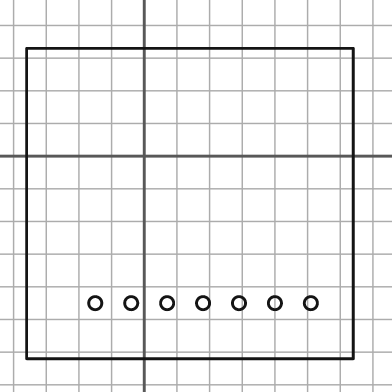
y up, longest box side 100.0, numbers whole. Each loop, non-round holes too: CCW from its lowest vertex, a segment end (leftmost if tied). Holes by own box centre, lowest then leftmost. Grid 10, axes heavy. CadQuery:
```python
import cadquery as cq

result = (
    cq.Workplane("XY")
    .moveTo(-36.0, -62.0)
    .lineTo(64.0, -62.0)
    .lineTo(64.0, 33.0)
    .lineTo(-36.0, 33.0)
    .close()
    .moveTo(-15.0, -45.0)
    .circle(2.0)
    .moveTo(-4.0, -45.0)
    .circle(2.0)
    .moveTo(7.0, -45.0)
    .circle(2.0)
    .moveTo(18.0, -45.0)
    .circle(2.0)
    .moveTo(29.0, -45.0)
    .circle(2.0)
    .moveTo(40.0, -45.0)
    .circle(2.0)
    .moveTo(51.0, -45.0)
    .circle(2.0)
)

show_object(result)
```